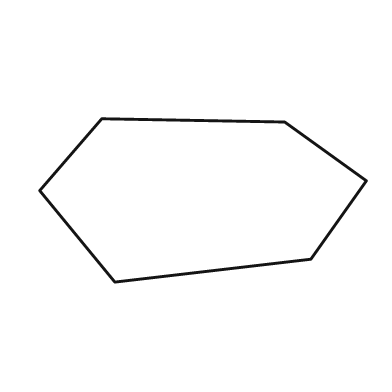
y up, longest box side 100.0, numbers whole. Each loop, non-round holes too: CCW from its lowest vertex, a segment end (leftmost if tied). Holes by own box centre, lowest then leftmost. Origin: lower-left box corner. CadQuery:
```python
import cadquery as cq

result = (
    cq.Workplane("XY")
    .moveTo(23.0, 0.0)
    .lineTo(83.0, 7.0)
    .lineTo(100.0, 31.0)
    .lineTo(75.0, 49.0)
    .lineTo(19.0, 50.0)
    .lineTo(0.0, 28.0)
    .close()
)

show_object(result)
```